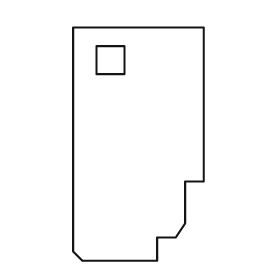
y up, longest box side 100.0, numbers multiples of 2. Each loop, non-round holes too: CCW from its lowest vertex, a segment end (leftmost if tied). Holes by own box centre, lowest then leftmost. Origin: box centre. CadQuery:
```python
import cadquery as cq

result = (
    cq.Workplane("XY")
    .moveTo(-24.0, -50.0)
    .lineTo(8.0, -50.0)
    .lineTo(8.0, -40.0)
    .lineTo(16.0, -40.0)
    .lineTo(20.0, -34.0)
    .lineTo(20.0, -16.0)
    .lineTo(28.0, -16.0)
    .lineTo(28.0, 50.0)
    .lineTo(-28.0, 50.0)
    .lineTo(-28.0, -46.0)
    .close()
    .moveTo(-18.0, 30.0)
    .lineTo(-6.0, 30.0)
    .lineTo(-6.0, 42.0)
    .lineTo(-18.0, 42.0)
    .close()
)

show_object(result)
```